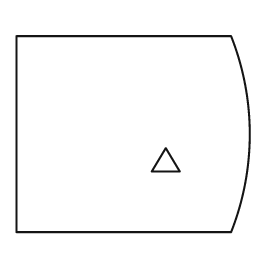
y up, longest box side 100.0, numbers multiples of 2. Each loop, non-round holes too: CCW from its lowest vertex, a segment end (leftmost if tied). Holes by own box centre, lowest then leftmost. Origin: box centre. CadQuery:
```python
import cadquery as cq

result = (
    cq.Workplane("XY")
    .moveTo(-50.0, -42.0)
    .lineTo(42.0, -42.0)
    .threePointArc((50.0, 0.0), (42.0, 42.0))
    .lineTo(-50.0, 42.0)
    .close()
    .moveTo(8.0, -16.0)
    .lineTo(20.0, -16.0)
    .lineTo(14.0, -6.0)
    .close()
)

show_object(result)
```